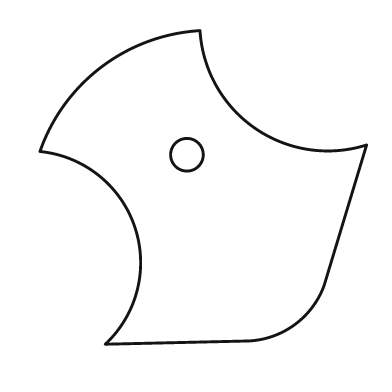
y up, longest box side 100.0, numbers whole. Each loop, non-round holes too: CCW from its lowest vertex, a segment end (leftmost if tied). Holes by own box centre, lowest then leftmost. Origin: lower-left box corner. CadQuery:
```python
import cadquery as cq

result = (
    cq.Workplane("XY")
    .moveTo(20.0, 0.0)
    .lineTo(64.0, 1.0)
    .threePointArc((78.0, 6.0), (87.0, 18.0))
    .lineTo(100.0, 61.0)
    .threePointArc((66.0, 66.0), (49.0, 96.0))
    .threePointArc((19.0, 85.0), (0.0, 59.0))
    .threePointArc((29.0, 36.0), (20.0, 0.0))
    .close()
    .moveTo(45.0, 58.0)
    .circle(5.0)
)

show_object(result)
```